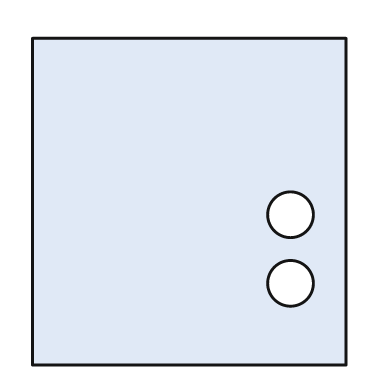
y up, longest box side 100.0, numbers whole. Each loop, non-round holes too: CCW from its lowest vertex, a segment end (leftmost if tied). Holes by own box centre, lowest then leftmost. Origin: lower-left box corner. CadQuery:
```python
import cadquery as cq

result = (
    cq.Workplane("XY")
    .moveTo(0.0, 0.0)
    .lineTo(96.0, 0.0)
    .lineTo(96.0, 100.0)
    .lineTo(0.0, 100.0)
    .close()
    .moveTo(79.0, 25.0)
    .circle(7.0)
    .moveTo(79.0, 46.0)
    .circle(7.0)
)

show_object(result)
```